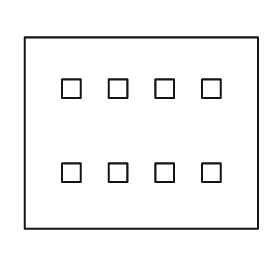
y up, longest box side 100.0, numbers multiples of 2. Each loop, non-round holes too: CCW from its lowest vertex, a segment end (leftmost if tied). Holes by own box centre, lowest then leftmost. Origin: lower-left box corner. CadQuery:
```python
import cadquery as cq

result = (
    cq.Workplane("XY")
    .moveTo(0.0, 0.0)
    .lineTo(100.0, 0.0)
    .lineTo(100.0, 82.0)
    .lineTo(0.0, 82.0)
    .close()
    .moveTo(16.0, 20.0)
    .lineTo(24.0, 20.0)
    .lineTo(24.0, 28.0)
    .lineTo(16.0, 28.0)
    .close()
    .moveTo(36.0, 20.0)
    .lineTo(44.0, 20.0)
    .lineTo(44.0, 28.0)
    .lineTo(36.0, 28.0)
    .close()
    .moveTo(56.0, 20.0)
    .lineTo(64.0, 20.0)
    .lineTo(64.0, 28.0)
    .lineTo(56.0, 28.0)
    .close()
    .moveTo(76.0, 20.0)
    .lineTo(84.0, 20.0)
    .lineTo(84.0, 28.0)
    .lineTo(76.0, 28.0)
    .close()
    .moveTo(16.0, 56.0)
    .lineTo(24.0, 56.0)
    .lineTo(24.0, 64.0)
    .lineTo(16.0, 64.0)
    .close()
    .moveTo(36.0, 56.0)
    .lineTo(44.0, 56.0)
    .lineTo(44.0, 64.0)
    .lineTo(36.0, 64.0)
    .close()
    .moveTo(56.0, 56.0)
    .lineTo(64.0, 56.0)
    .lineTo(64.0, 64.0)
    .lineTo(56.0, 64.0)
    .close()
    .moveTo(76.0, 56.0)
    .lineTo(84.0, 56.0)
    .lineTo(84.0, 64.0)
    .lineTo(76.0, 64.0)
    .close()
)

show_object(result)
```